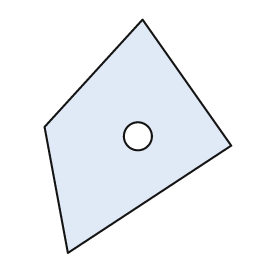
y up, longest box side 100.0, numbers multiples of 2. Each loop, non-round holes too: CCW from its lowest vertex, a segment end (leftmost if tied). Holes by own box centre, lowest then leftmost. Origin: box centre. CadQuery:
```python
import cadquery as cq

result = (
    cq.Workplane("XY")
    .moveTo(-30.0, -50.0)
    .lineTo(40.0, -4.0)
    .lineTo(2.0, 50.0)
    .lineTo(-40.0, 4.0)
    .close()
    .moveTo(0.0, 0.0)
    .circle(6.0)
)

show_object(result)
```